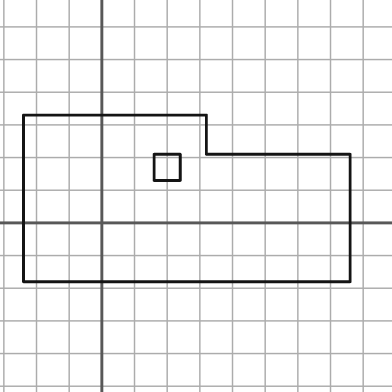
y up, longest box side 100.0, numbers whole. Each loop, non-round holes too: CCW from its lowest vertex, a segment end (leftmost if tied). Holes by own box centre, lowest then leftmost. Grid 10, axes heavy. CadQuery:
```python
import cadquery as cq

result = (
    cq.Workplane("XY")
    .moveTo(-24.0, -18.0)
    .lineTo(76.0, -18.0)
    .lineTo(76.0, 21.0)
    .lineTo(32.0, 21.0)
    .lineTo(32.0, 33.0)
    .lineTo(-24.0, 33.0)
    .close()
    .moveTo(16.0, 13.0)
    .lineTo(24.0, 13.0)
    .lineTo(24.0, 21.0)
    .lineTo(16.0, 21.0)
    .close()
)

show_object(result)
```